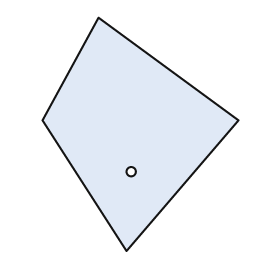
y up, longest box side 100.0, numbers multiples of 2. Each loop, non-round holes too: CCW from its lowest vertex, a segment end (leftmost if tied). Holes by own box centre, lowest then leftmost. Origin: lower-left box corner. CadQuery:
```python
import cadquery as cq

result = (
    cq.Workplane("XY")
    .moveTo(36.0, 0.0)
    .lineTo(84.0, 56.0)
    .lineTo(24.0, 100.0)
    .lineTo(0.0, 56.0)
    .close()
    .moveTo(38.0, 34.0)
    .circle(2.0)
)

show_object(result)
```